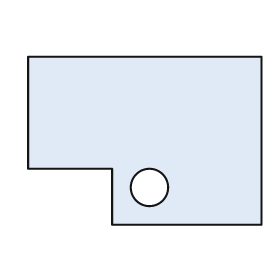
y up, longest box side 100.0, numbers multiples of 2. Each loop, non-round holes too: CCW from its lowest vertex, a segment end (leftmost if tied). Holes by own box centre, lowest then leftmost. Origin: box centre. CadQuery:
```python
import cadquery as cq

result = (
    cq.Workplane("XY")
    .moveTo(-14.0, -36.0)
    .lineTo(50.0, -36.0)
    .lineTo(50.0, 36.0)
    .lineTo(-50.0, 36.0)
    .lineTo(-50.0, -12.0)
    .lineTo(-14.0, -12.0)
    .close()
    .moveTo(2.0, -20.0)
    .circle(8.0)
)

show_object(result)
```